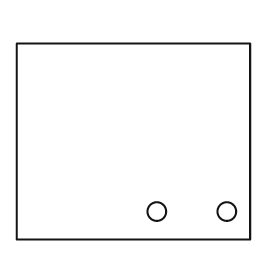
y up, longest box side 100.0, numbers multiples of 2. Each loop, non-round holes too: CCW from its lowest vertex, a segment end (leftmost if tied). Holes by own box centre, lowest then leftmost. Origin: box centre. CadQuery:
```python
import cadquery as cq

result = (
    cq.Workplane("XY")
    .moveTo(-50.0, -42.0)
    .lineTo(50.0, -42.0)
    .lineTo(50.0, 42.0)
    .lineTo(-50.0, 42.0)
    .close()
    .moveTo(10.0, -30.0)
    .circle(4.0)
    .moveTo(40.0, -30.0)
    .circle(4.0)
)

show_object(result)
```